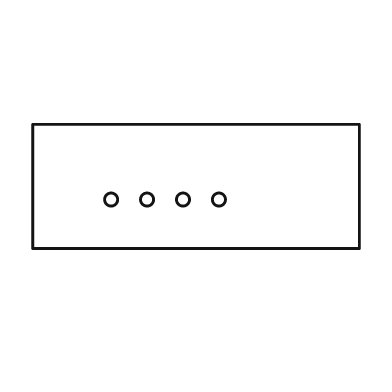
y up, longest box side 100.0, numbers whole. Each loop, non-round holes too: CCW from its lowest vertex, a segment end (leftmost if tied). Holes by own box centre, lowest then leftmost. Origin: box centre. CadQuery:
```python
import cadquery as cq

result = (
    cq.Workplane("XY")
    .moveTo(-50.0, -19.0)
    .lineTo(50.0, -19.0)
    .lineTo(50.0, 19.0)
    .lineTo(-50.0, 19.0)
    .close()
    .moveTo(-26.0, -4.0)
    .circle(2.0)
    .moveTo(-15.0, -4.0)
    .circle(2.0)
    .moveTo(-4.0, -4.0)
    .circle(2.0)
    .moveTo(7.0, -4.0)
    .circle(2.0)
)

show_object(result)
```